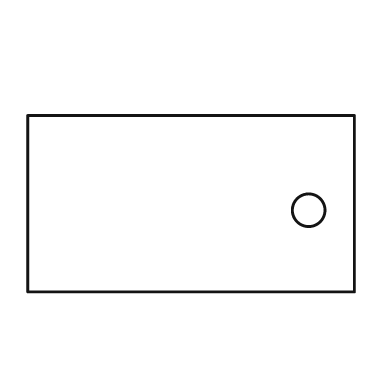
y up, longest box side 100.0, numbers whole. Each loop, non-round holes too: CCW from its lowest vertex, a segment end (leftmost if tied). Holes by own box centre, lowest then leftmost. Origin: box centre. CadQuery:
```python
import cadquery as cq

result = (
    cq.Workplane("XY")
    .moveTo(-50.0, -27.0)
    .lineTo(50.0, -27.0)
    .lineTo(50.0, 27.0)
    .lineTo(-50.0, 27.0)
    .close()
    .moveTo(36.0, -2.0)
    .circle(5.0)
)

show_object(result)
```